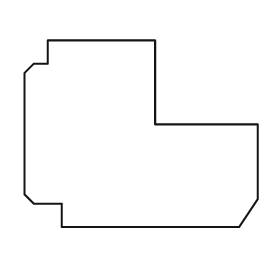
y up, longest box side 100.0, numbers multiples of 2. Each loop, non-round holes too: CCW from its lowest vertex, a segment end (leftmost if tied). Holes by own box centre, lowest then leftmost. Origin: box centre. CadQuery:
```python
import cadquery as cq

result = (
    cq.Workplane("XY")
    .moveTo(-34.0, -40.0)
    .lineTo(42.0, -40.0)
    .lineTo(50.0, -28.0)
    .lineTo(50.0, 4.0)
    .lineTo(6.0, 4.0)
    .lineTo(6.0, 40.0)
    .lineTo(-40.0, 40.0)
    .lineTo(-40.0, 30.0)
    .lineTo(-46.0, 30.0)
    .lineTo(-50.0, 26.0)
    .lineTo(-50.0, -26.0)
    .lineTo(-46.0, -30.0)
    .lineTo(-34.0, -30.0)
    .close()
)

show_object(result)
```